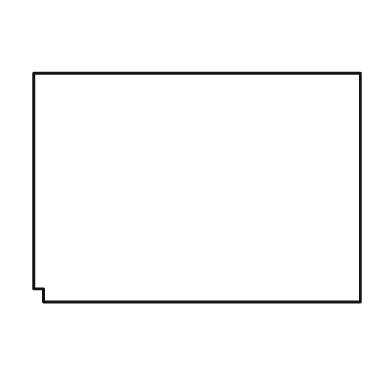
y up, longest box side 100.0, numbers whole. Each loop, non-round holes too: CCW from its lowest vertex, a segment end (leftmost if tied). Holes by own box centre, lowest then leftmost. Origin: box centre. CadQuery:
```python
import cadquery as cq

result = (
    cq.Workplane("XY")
    .moveTo(-47.0, -35.0)
    .lineTo(50.0, -35.0)
    .lineTo(50.0, 35.0)
    .lineTo(-50.0, 35.0)
    .lineTo(-50.0, -31.0)
    .lineTo(-47.0, -31.0)
    .close()
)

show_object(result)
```